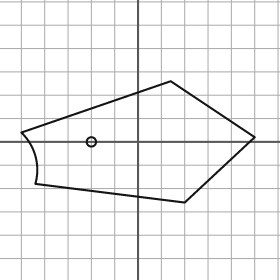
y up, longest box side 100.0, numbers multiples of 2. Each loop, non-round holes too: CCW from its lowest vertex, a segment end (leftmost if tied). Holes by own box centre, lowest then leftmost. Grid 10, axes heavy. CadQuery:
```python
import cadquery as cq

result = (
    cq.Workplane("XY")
    .moveTo(20.0, -26.0)
    .lineTo(50.0, 2.0)
    .lineTo(14.0, 26.0)
    .lineTo(-50.0, 4.0)
    .threePointArc((-44.0, -6.0), (-44.0, -18.0))
    .close()
    .moveTo(-20.0, 0.0)
    .circle(2.0)
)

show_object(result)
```